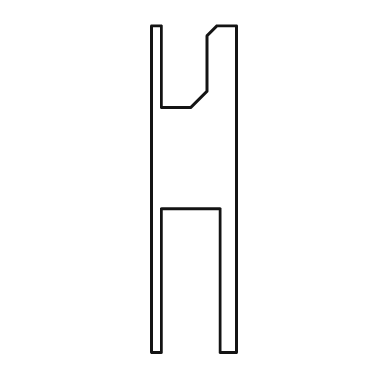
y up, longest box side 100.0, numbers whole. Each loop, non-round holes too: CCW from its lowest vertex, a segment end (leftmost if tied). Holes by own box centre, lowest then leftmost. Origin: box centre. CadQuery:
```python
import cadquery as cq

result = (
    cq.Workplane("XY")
    .moveTo(-13.0, -50.0)
    .lineTo(-10.0, -50.0)
    .lineTo(-10.0, -6.0)
    .lineTo(8.0, -6.0)
    .lineTo(8.0, -50.0)
    .lineTo(13.0, -50.0)
    .lineTo(13.0, 50.0)
    .lineTo(7.0, 50.0)
    .lineTo(4.0, 47.0)
    .lineTo(4.0, 30.0)
    .lineTo(-1.0, 25.0)
    .lineTo(-10.0, 25.0)
    .lineTo(-10.0, 50.0)
    .lineTo(-13.0, 50.0)
    .close()
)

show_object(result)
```